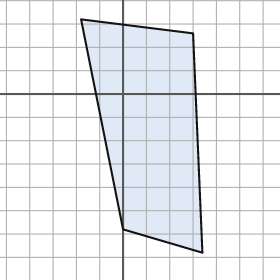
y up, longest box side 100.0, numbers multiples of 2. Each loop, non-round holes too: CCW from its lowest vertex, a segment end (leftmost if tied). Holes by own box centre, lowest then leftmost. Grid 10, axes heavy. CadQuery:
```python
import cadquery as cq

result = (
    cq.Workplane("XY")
    .moveTo(34.0, -68.0)
    .lineTo(30.0, 26.0)
    .lineTo(-18.0, 32.0)
    .lineTo(0.0, -58.0)
    .close()
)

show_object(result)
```